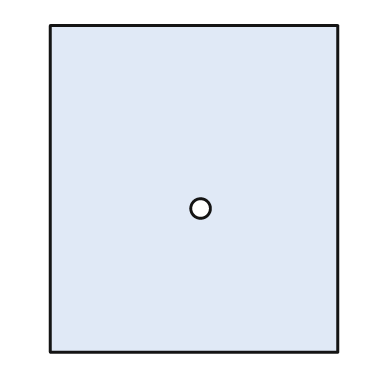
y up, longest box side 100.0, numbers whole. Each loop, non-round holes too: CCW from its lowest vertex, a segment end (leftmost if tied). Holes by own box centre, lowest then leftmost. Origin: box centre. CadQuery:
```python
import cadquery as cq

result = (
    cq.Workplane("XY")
    .moveTo(-44.0, -50.0)
    .lineTo(44.0, -50.0)
    .lineTo(44.0, 50.0)
    .lineTo(-44.0, 50.0)
    .close()
    .moveTo(2.0, -6.0)
    .circle(3.0)
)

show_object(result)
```